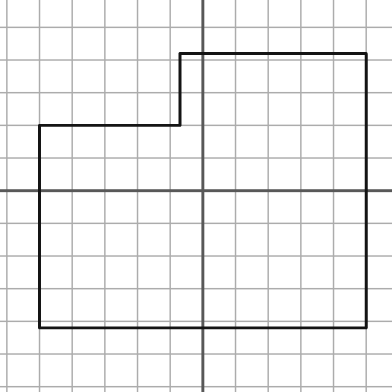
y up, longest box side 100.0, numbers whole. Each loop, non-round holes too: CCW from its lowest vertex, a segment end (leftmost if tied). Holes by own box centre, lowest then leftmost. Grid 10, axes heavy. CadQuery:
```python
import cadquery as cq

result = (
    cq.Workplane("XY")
    .moveTo(-50.0, -42.0)
    .lineTo(50.0, -42.0)
    .lineTo(50.0, 42.0)
    .lineTo(-7.0, 42.0)
    .lineTo(-7.0, 20.0)
    .lineTo(-50.0, 20.0)
    .close()
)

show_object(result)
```